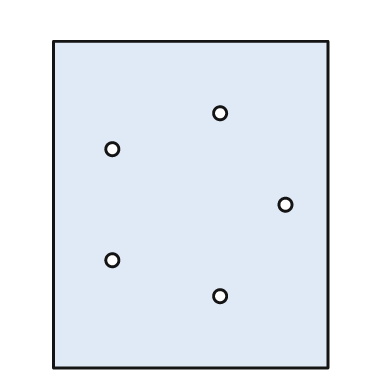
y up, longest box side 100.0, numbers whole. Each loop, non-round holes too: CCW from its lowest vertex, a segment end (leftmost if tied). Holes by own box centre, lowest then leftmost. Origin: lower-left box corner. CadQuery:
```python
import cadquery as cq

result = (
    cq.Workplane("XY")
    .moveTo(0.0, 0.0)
    .lineTo(84.0, 0.0)
    .lineTo(84.0, 100.0)
    .lineTo(0.0, 100.0)
    .close()
    .moveTo(51.0, 22.0)
    .circle(2.0)
    .moveTo(18.0, 33.0)
    .circle(2.0)
    .moveTo(71.0, 50.0)
    .circle(2.0)
    .moveTo(18.0, 67.0)
    .circle(2.0)
    .moveTo(51.0, 78.0)
    .circle(2.0)
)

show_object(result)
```